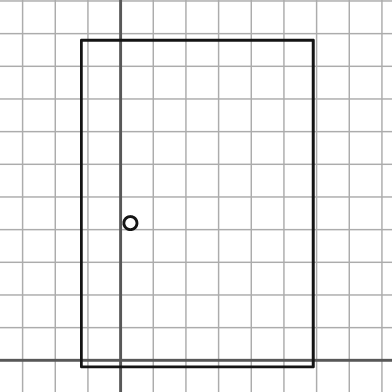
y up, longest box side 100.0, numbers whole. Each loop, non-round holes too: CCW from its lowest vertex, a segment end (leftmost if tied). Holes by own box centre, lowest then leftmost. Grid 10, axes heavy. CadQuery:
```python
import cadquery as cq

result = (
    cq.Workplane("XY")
    .moveTo(-12.0, -2.0)
    .lineTo(59.0, -2.0)
    .lineTo(59.0, 98.0)
    .lineTo(-12.0, 98.0)
    .close()
    .moveTo(3.0, 42.0)
    .circle(2.0)
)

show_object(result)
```